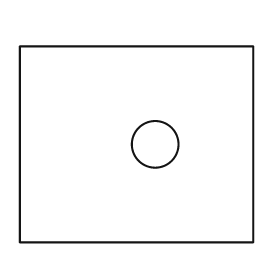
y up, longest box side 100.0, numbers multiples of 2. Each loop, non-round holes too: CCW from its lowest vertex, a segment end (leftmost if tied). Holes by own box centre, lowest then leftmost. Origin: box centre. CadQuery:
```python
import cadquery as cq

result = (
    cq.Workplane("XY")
    .moveTo(-50.0, -42.0)
    .lineTo(50.0, -42.0)
    .lineTo(50.0, 42.0)
    .lineTo(-50.0, 42.0)
    .close()
    .moveTo(8.0, 0.0)
    .circle(10.0)
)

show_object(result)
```